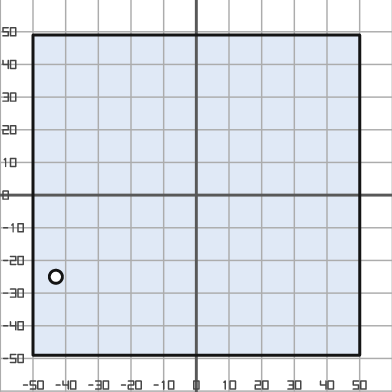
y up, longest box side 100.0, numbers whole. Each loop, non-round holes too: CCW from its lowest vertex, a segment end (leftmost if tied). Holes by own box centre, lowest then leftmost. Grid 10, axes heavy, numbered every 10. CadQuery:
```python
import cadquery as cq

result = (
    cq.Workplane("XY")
    .moveTo(-50.0, -49.0)
    .lineTo(50.0, -49.0)
    .lineTo(50.0, 49.0)
    .lineTo(-50.0, 49.0)
    .close()
    .moveTo(-43.0, -25.0)
    .circle(2.0)
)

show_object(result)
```